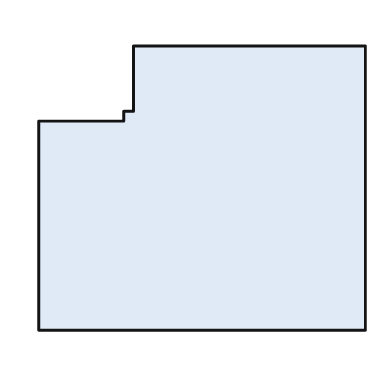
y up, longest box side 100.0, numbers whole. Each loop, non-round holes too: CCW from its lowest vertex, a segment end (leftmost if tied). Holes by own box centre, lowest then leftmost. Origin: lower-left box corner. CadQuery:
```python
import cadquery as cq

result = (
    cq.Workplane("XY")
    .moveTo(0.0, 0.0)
    .lineTo(100.0, 0.0)
    .lineTo(100.0, 87.0)
    .lineTo(29.0, 87.0)
    .lineTo(29.0, 67.0)
    .lineTo(26.0, 67.0)
    .lineTo(26.0, 64.0)
    .lineTo(0.0, 64.0)
    .close()
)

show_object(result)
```